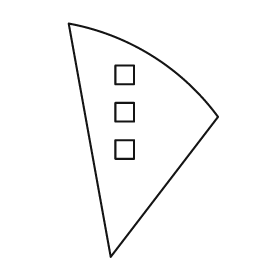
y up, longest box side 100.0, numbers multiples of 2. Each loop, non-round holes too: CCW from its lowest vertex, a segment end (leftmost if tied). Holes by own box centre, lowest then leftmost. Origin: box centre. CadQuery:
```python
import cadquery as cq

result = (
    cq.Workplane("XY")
    .moveTo(-14.0, -50.0)
    .lineTo(32.0, 10.0)
    .threePointArc((4.0, 36.0), (-32.0, 50.0))
    .close()
    .moveTo(-12.0, -8.0)
    .lineTo(-4.0, -8.0)
    .lineTo(-4.0, 0.0)
    .lineTo(-12.0, 0.0)
    .close()
    .moveTo(-12.0, 8.0)
    .lineTo(-4.0, 8.0)
    .lineTo(-4.0, 16.0)
    .lineTo(-12.0, 16.0)
    .close()
    .moveTo(-12.0, 24.0)
    .lineTo(-4.0, 24.0)
    .lineTo(-4.0, 32.0)
    .lineTo(-12.0, 32.0)
    .close()
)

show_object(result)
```